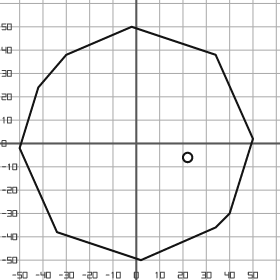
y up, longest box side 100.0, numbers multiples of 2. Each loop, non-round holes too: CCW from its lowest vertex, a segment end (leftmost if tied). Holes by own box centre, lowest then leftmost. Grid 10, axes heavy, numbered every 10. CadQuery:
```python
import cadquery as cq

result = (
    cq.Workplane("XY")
    .moveTo(2.0, -50.0)
    .lineTo(34.0, -36.0)
    .lineTo(40.0, -30.0)
    .lineTo(50.0, 2.0)
    .lineTo(34.0, 38.0)
    .lineTo(-2.0, 50.0)
    .lineTo(-30.0, 38.0)
    .lineTo(-42.0, 24.0)
    .lineTo(-50.0, -2.0)
    .lineTo(-34.0, -38.0)
    .close()
    .moveTo(22.0, -6.0)
    .circle(2.0)
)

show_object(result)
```